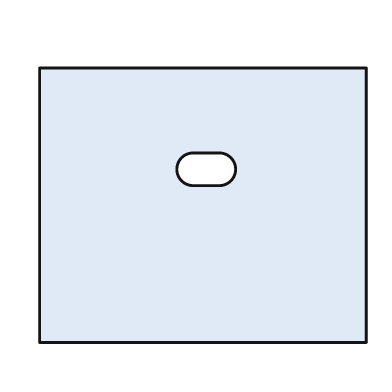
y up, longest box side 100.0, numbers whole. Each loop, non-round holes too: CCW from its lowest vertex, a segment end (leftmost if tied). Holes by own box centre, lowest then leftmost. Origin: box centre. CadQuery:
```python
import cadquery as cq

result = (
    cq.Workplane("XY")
    .moveTo(-50.0, -42.0)
    .lineTo(50.0, -42.0)
    .lineTo(50.0, 42.0)
    .lineTo(-50.0, 42.0)
    .close()
    .moveTo(-3.0, 6.0)
    .lineTo(5.0, 6.0)
    .threePointArc((10.0, 11.0), (5.0, 16.0))
    .lineTo(-3.0, 16.0)
    .threePointArc((-8.0, 11.0), (-3.0, 6.0))
    .close()
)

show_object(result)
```